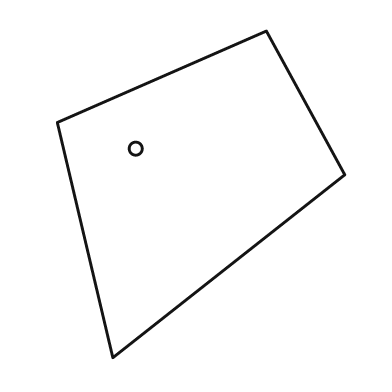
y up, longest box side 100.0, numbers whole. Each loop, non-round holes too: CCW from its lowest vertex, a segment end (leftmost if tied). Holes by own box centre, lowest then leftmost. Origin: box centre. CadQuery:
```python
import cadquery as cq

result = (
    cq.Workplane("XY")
    .moveTo(-27.0, -50.0)
    .lineTo(44.0, 6.0)
    .lineTo(20.0, 50.0)
    .lineTo(-44.0, 22.0)
    .close()
    .moveTo(-20.0, 14.0)
    .circle(2.0)
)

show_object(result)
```